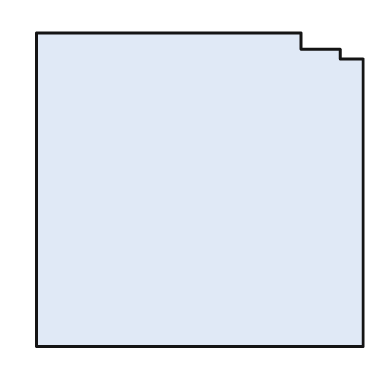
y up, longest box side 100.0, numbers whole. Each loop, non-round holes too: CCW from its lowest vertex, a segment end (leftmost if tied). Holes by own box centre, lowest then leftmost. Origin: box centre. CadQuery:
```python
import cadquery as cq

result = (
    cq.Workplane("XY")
    .moveTo(-50.0, -48.0)
    .lineTo(50.0, -48.0)
    .lineTo(50.0, 40.0)
    .lineTo(43.0, 40.0)
    .lineTo(43.0, 43.0)
    .lineTo(31.0, 43.0)
    .lineTo(31.0, 48.0)
    .lineTo(-50.0, 48.0)
    .close()
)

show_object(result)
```